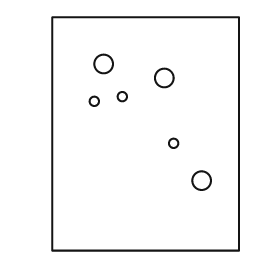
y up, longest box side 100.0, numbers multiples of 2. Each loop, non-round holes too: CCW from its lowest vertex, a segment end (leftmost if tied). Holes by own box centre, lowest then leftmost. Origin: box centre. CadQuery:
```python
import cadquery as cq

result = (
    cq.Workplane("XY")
    .moveTo(-40.0, -50.0)
    .lineTo(40.0, -50.0)
    .lineTo(40.0, 50.0)
    .lineTo(-40.0, 50.0)
    .close()
    .moveTo(24.0, -20.0)
    .circle(4.0)
    .moveTo(12.0, -4.0)
    .circle(2.0)
    .moveTo(-22.0, 14.0)
    .circle(2.0)
    .moveTo(-10.0, 16.0)
    .circle(2.0)
    .moveTo(8.0, 24.0)
    .circle(4.0)
    .moveTo(-18.0, 30.0)
    .circle(4.0)
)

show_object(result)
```